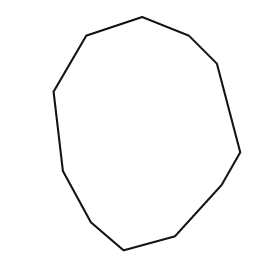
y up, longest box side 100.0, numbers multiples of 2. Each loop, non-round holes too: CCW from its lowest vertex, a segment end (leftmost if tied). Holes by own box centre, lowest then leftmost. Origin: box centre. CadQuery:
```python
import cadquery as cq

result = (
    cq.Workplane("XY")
    .moveTo(-10.0, -50.0)
    .lineTo(12.0, -44.0)
    .lineTo(32.0, -22.0)
    .lineTo(40.0, -8.0)
    .lineTo(30.0, 30.0)
    .lineTo(18.0, 42.0)
    .lineTo(-2.0, 50.0)
    .lineTo(-26.0, 42.0)
    .lineTo(-40.0, 18.0)
    .lineTo(-36.0, -16.0)
    .lineTo(-24.0, -38.0)
    .close()
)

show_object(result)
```